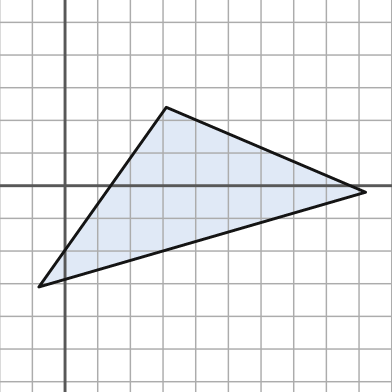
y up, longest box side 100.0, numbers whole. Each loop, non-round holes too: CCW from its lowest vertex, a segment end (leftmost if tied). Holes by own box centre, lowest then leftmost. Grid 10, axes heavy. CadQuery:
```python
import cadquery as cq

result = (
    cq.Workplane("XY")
    .moveTo(-8.0, -31.0)
    .lineTo(92.0, -2.0)
    .lineTo(31.0, 24.0)
    .close()
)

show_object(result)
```